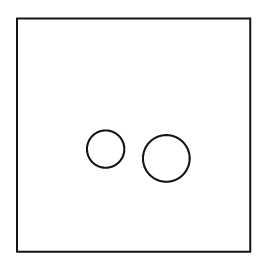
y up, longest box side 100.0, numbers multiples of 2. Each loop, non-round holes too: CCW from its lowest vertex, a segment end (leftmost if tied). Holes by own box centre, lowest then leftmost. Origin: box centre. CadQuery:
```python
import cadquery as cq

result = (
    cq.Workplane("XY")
    .moveTo(-50.0, -50.0)
    .lineTo(50.0, -50.0)
    .lineTo(50.0, 50.0)
    .lineTo(-50.0, 50.0)
    .close()
    .moveTo(14.0, -10.0)
    .circle(10.0)
    .moveTo(-12.0, -6.0)
    .circle(8.0)
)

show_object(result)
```